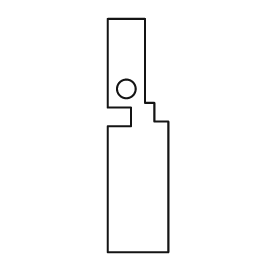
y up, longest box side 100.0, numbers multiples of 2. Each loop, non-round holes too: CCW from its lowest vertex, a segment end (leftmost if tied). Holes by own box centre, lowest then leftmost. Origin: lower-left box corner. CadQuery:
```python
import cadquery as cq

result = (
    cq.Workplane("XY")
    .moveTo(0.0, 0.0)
    .lineTo(26.0, 0.0)
    .lineTo(26.0, 56.0)
    .lineTo(20.0, 56.0)
    .lineTo(20.0, 64.0)
    .lineTo(16.0, 64.0)
    .lineTo(16.0, 100.0)
    .lineTo(0.0, 100.0)
    .lineTo(0.0, 62.0)
    .lineTo(10.0, 62.0)
    .lineTo(10.0, 54.0)
    .lineTo(0.0, 54.0)
    .close()
    .moveTo(8.0, 70.0)
    .circle(4.0)
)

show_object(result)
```